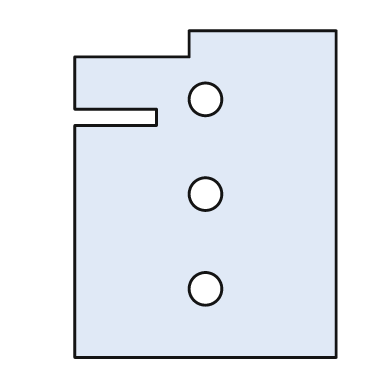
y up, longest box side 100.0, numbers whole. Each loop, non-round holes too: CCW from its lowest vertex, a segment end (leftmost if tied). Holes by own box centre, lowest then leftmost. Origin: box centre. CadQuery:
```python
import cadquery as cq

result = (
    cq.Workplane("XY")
    .moveTo(-40.0, -50.0)
    .lineTo(40.0, -50.0)
    .lineTo(40.0, 50.0)
    .lineTo(-5.0, 50.0)
    .lineTo(-5.0, 42.0)
    .lineTo(-40.0, 42.0)
    .lineTo(-40.0, 26.0)
    .lineTo(-15.0, 26.0)
    .lineTo(-15.0, 21.0)
    .lineTo(-40.0, 21.0)
    .close()
    .moveTo(0.0, -29.0)
    .circle(5.0)
    .moveTo(0.0, 0.0)
    .circle(5.0)
    .moveTo(0.0, 29.0)
    .circle(5.0)
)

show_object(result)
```